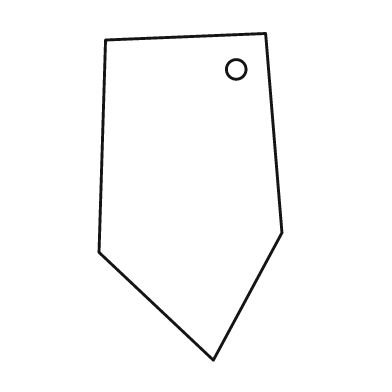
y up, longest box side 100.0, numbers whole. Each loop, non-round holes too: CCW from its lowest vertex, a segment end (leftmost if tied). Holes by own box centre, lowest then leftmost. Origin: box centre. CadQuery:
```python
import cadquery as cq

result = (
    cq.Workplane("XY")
    .moveTo(7.0, -50.0)
    .lineTo(28.0, -11.0)
    .lineTo(23.0, 50.0)
    .lineTo(-26.0, 48.0)
    .lineTo(-28.0, -17.0)
    .close()
    .moveTo(14.0, 39.0)
    .circle(3.0)
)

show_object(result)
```